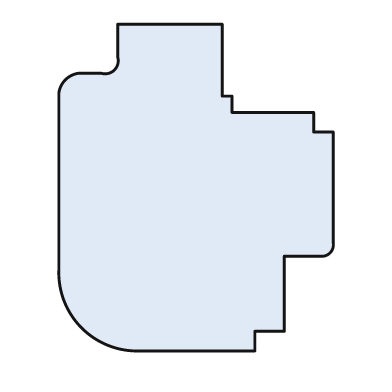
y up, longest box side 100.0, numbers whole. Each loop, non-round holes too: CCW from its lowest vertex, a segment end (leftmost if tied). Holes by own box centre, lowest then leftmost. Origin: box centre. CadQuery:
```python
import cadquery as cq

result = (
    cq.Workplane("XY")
    .moveTo(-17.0, -50.0)
    .lineTo(18.0, -50.0)
    .lineTo(18.0, -44.0)
    .lineTo(27.0, -44.0)
    .lineTo(27.0, -21.0)
    .lineTo(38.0, -21.0)
    .threePointArc((41.0, -20.0), (42.0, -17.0))
    .lineTo(42.0, 17.0)
    .lineTo(36.0, 17.0)
    .lineTo(36.0, 23.0)
    .lineTo(11.0, 23.0)
    .lineTo(11.0, 28.0)
    .lineTo(8.0, 28.0)
    .lineTo(8.0, 50.0)
    .lineTo(-24.0, 50.0)
    .lineTo(-24.0, 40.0)
    .threePointArc((-25.0, 36.0), (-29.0, 35.0))
    .lineTo(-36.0, 35.0)
    .threePointArc((-40.0, 33.0), (-42.0, 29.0))
    .lineTo(-42.0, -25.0)
    .threePointArc((-35.0, -43.0), (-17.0, -50.0))
    .close()
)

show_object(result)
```